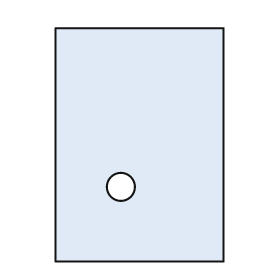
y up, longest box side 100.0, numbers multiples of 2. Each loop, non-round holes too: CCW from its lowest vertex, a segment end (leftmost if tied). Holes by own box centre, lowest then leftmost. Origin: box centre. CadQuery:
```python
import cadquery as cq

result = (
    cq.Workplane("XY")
    .moveTo(-36.0, -50.0)
    .lineTo(36.0, -50.0)
    .lineTo(36.0, 50.0)
    .lineTo(-36.0, 50.0)
    .close()
    .moveTo(-8.0, -18.0)
    .circle(6.0)
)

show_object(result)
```